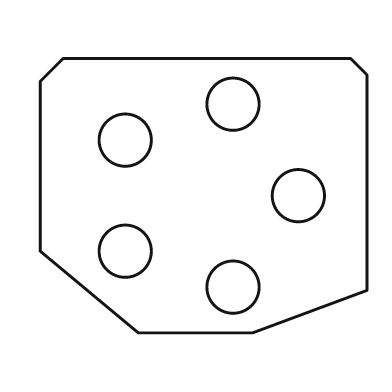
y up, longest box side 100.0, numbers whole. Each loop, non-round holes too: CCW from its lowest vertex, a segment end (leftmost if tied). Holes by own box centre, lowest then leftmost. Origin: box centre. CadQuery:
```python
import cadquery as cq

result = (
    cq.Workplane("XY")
    .moveTo(-20.0, -42.0)
    .lineTo(15.0, -42.0)
    .lineTo(50.0, -29.0)
    .lineTo(50.0, 37.0)
    .lineTo(45.0, 42.0)
    .lineTo(-43.0, 42.0)
    .lineTo(-50.0, 35.0)
    .lineTo(-50.0, -17.0)
    .close()
    .moveTo(9.0, -28.0)
    .circle(8.0)
    .moveTo(-24.0, -17.0)
    .circle(8.0)
    .moveTo(29.0, 0.0)
    .circle(8.0)
    .moveTo(-24.0, 17.0)
    .circle(8.0)
    .moveTo(9.0, 28.0)
    .circle(8.0)
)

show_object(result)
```